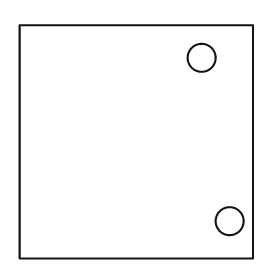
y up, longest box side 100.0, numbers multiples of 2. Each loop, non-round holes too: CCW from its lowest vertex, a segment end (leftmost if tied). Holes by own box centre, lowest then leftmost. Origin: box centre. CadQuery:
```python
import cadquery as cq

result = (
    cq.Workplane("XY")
    .moveTo(-50.0, -50.0)
    .lineTo(50.0, -50.0)
    .lineTo(50.0, 50.0)
    .lineTo(-50.0, 50.0)
    .close()
    .moveTo(40.0, -34.0)
    .circle(6.0)
    .moveTo(28.0, 36.0)
    .circle(6.0)
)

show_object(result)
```